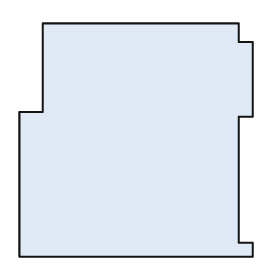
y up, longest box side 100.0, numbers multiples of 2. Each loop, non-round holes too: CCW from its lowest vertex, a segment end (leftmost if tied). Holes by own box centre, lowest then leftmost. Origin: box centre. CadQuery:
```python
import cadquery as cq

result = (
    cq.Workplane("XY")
    .moveTo(-50.0, -50.0)
    .lineTo(50.0, -50.0)
    .lineTo(50.0, -44.0)
    .lineTo(44.0, -44.0)
    .lineTo(44.0, 10.0)
    .lineTo(50.0, 10.0)
    .lineTo(50.0, 42.0)
    .lineTo(44.0, 42.0)
    .lineTo(44.0, 50.0)
    .lineTo(-40.0, 50.0)
    .lineTo(-40.0, 12.0)
    .lineTo(-50.0, 12.0)
    .close()
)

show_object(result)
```